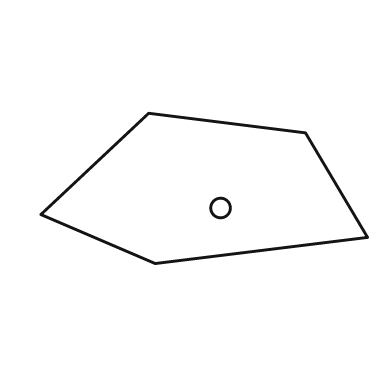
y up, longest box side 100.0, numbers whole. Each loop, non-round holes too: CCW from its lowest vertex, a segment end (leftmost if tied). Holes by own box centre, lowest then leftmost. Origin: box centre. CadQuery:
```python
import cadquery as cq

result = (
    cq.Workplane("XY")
    .moveTo(-15.0, -23.0)
    .lineTo(50.0, -15.0)
    .lineTo(31.0, 17.0)
    .lineTo(-17.0, 23.0)
    .lineTo(-50.0, -8.0)
    .close()
    .moveTo(5.0, -6.0)
    .circle(3.0)
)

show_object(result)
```